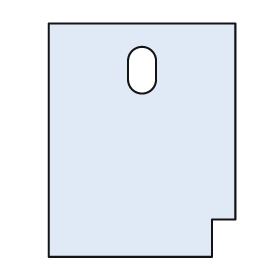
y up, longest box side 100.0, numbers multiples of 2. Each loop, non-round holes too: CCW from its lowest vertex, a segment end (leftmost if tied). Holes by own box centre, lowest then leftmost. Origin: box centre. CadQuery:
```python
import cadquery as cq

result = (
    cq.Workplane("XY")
    .moveTo(-40.0, -50.0)
    .lineTo(30.0, -50.0)
    .lineTo(30.0, -34.0)
    .lineTo(40.0, -34.0)
    .lineTo(40.0, 50.0)
    .lineTo(-40.0, 50.0)
    .close()
    .moveTo(-6.0, 26.0)
    .threePointArc((0.0, 20.0), (6.0, 26.0))
    .lineTo(6.0, 34.0)
    .threePointArc((0.0, 40.0), (-6.0, 34.0))
    .close()
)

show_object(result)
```